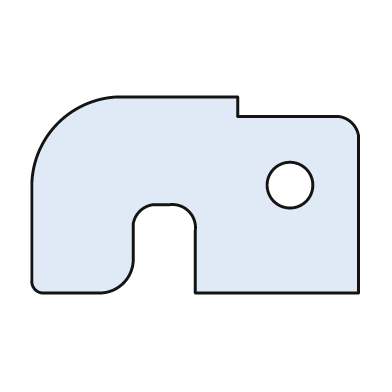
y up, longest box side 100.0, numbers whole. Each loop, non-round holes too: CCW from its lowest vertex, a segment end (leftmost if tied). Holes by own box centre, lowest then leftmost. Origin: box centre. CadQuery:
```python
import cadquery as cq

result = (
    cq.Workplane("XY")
    .moveTo(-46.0, -30.0)
    .lineTo(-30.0, -30.0)
    .threePointArc((-22.0, -27.0), (-19.0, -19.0))
    .lineTo(-19.0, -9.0)
    .threePointArc((-17.0, -5.0), (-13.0, -3.0))
    .lineTo(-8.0, -3.0)
    .threePointArc((-2.0, -5.0), (0.0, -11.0))
    .lineTo(0.0, -30.0)
    .lineTo(50.0, -30.0)
    .lineTo(50.0, 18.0)
    .threePointArc((48.0, 22.0), (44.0, 24.0))
    .lineTo(13.0, 24.0)
    .lineTo(13.0, 30.0)
    .lineTo(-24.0, 30.0)
    .threePointArc((-42.0, 22.0), (-50.0, 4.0))
    .lineTo(-50.0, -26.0)
    .threePointArc((-49.0, -29.0), (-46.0, -30.0))
    .close()
    .moveTo(29.0, 3.0)
    .circle(7.0)
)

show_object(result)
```